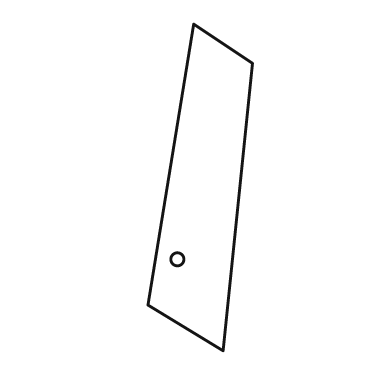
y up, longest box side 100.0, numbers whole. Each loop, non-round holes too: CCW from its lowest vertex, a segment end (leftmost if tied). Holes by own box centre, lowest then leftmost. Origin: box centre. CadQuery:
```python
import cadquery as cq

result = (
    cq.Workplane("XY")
    .moveTo(7.0, -50.0)
    .lineTo(16.0, 38.0)
    .lineTo(-2.0, 50.0)
    .lineTo(-16.0, -36.0)
    .close()
    .moveTo(-7.0, -22.0)
    .circle(2.0)
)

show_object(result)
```